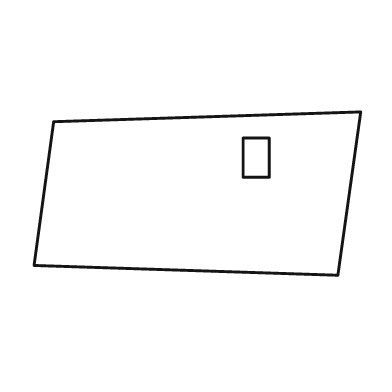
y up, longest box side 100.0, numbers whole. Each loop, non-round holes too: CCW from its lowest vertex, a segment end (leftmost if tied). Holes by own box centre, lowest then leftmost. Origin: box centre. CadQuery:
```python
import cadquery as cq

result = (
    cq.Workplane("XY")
    .moveTo(43.0, -25.0)
    .lineTo(50.0, 25.0)
    .lineTo(-44.0, 22.0)
    .lineTo(-50.0, -22.0)
    .close()
    .moveTo(14.0, 5.0)
    .lineTo(22.0, 5.0)
    .lineTo(22.0, 17.0)
    .lineTo(14.0, 17.0)
    .close()
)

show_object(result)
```